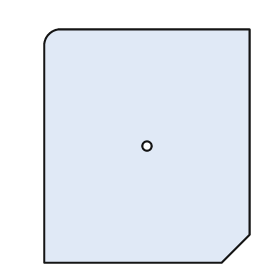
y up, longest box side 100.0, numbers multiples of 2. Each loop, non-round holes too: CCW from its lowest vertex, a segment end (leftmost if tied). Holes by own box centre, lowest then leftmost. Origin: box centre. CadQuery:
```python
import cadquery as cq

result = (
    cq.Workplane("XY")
    .moveTo(-44.0, -50.0)
    .lineTo(32.0, -50.0)
    .lineTo(44.0, -38.0)
    .lineTo(44.0, 50.0)
    .lineTo(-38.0, 50.0)
    .threePointArc((-42.0, 48.0), (-44.0, 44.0))
    .close()
    .moveTo(0.0, 0.0)
    .circle(2.0)
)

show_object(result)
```